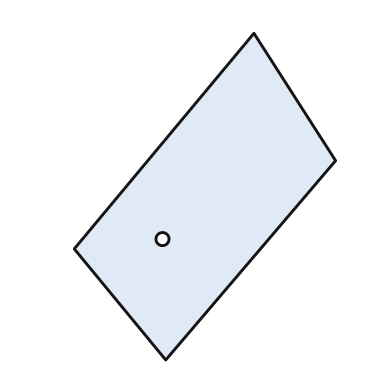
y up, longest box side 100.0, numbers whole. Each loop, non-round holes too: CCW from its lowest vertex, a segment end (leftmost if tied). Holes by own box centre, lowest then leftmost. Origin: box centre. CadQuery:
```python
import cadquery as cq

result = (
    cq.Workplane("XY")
    .moveTo(-12.0, -50.0)
    .lineTo(40.0, 11.0)
    .lineTo(15.0, 50.0)
    .lineTo(-40.0, -16.0)
    .close()
    .moveTo(-13.0, -13.0)
    .circle(2.0)
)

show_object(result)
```